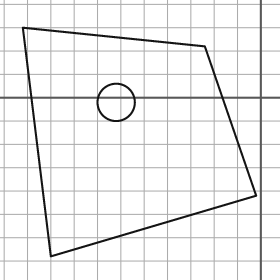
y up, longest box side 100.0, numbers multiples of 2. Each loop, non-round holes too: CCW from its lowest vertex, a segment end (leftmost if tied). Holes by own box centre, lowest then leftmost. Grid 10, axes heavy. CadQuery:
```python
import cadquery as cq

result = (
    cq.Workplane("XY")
    .moveTo(-90.0, -68.0)
    .lineTo(-2.0, -42.0)
    .lineTo(-24.0, 22.0)
    .lineTo(-102.0, 30.0)
    .close()
    .moveTo(-62.0, -2.0)
    .circle(8.0)
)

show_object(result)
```